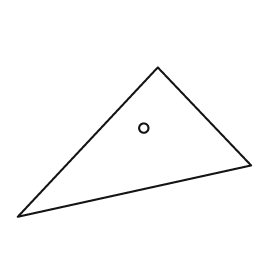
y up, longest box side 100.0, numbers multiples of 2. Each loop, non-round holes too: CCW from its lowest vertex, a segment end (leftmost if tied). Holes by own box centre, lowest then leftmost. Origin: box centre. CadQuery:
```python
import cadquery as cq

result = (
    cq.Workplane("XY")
    .moveTo(-50.0, -32.0)
    .lineTo(50.0, -10.0)
    .lineTo(10.0, 32.0)
    .close()
    .moveTo(4.0, 6.0)
    .circle(2.0)
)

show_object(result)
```